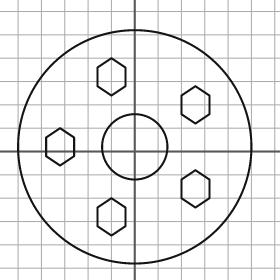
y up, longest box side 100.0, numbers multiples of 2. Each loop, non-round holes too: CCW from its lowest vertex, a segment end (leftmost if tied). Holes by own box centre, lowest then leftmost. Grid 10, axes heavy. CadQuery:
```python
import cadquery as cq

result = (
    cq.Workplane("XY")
    .moveTo(0.0, 2.0)
    .circle(50.0)
    .moveTo(-10.0, -36.0)
    .lineTo(-4.0, -32.0)
    .lineTo(-4.0, -24.0)
    .lineTo(-10.0, -20.0)
    .lineTo(-16.0, -24.0)
    .lineTo(-16.0, -32.0)
    .close()
    .moveTo(26.0, -24.0)
    .lineTo(32.0, -20.0)
    .lineTo(32.0, -12.0)
    .lineTo(26.0, -8.0)
    .lineTo(20.0, -12.0)
    .lineTo(20.0, -20.0)
    .close()
    .moveTo(-32.0, -6.0)
    .lineTo(-26.0, -2.0)
    .lineTo(-26.0, 6.0)
    .lineTo(-32.0, 10.0)
    .lineTo(-38.0, 6.0)
    .lineTo(-38.0, -2.0)
    .close()
    .moveTo(0.0, 2.0)
    .circle(14.0)
    .moveTo(26.0, 12.0)
    .lineTo(32.0, 16.0)
    .lineTo(32.0, 24.0)
    .lineTo(26.0, 28.0)
    .lineTo(20.0, 24.0)
    .lineTo(20.0, 16.0)
    .close()
    .moveTo(-10.0, 24.0)
    .lineTo(-4.0, 28.0)
    .lineTo(-4.0, 36.0)
    .lineTo(-10.0, 40.0)
    .lineTo(-16.0, 36.0)
    .lineTo(-16.0, 28.0)
    .close()
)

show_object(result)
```